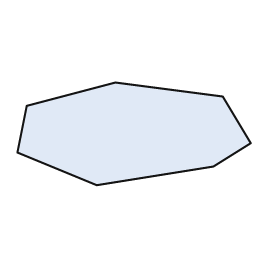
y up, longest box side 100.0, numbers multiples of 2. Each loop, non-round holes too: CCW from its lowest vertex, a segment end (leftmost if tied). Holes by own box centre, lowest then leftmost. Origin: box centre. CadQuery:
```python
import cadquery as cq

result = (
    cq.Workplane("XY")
    .moveTo(-16.0, -22.0)
    .lineTo(34.0, -14.0)
    .lineTo(50.0, -4.0)
    .lineTo(38.0, 16.0)
    .lineTo(-8.0, 22.0)
    .lineTo(-46.0, 12.0)
    .lineTo(-50.0, -8.0)
    .close()
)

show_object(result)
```